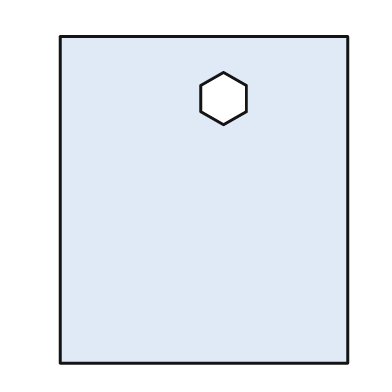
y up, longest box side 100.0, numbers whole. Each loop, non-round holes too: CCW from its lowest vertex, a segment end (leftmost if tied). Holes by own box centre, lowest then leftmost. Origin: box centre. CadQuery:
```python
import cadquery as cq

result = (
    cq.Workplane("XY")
    .moveTo(-44.0, -50.0)
    .lineTo(44.0, -50.0)
    .lineTo(44.0, 50.0)
    .lineTo(-44.0, 50.0)
    .close()
    .moveTo(6.0, 23.0)
    .lineTo(13.0, 27.0)
    .lineTo(13.0, 35.0)
    .lineTo(6.0, 39.0)
    .lineTo(-1.0, 35.0)
    .lineTo(-1.0, 27.0)
    .close()
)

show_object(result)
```